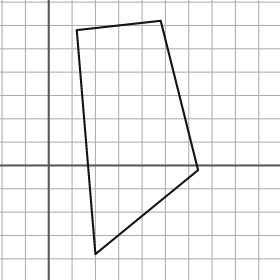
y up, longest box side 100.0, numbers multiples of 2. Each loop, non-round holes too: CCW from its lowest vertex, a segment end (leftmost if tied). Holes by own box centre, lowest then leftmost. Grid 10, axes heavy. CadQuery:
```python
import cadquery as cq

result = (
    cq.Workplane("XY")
    .moveTo(20.0, -38.0)
    .lineTo(64.0, -2.0)
    .lineTo(48.0, 62.0)
    .lineTo(12.0, 58.0)
    .close()
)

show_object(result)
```